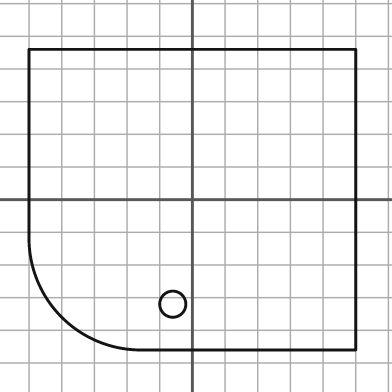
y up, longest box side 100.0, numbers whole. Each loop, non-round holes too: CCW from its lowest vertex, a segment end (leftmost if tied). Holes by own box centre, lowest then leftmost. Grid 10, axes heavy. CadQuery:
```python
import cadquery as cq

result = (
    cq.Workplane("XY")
    .moveTo(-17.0, -46.0)
    .lineTo(50.0, -46.0)
    .lineTo(50.0, 46.0)
    .lineTo(-50.0, 46.0)
    .lineTo(-50.0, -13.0)
    .threePointArc((-40.0, -36.0), (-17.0, -46.0))
    .close()
    .moveTo(-6.0, -32.0)
    .circle(4.0)
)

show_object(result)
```